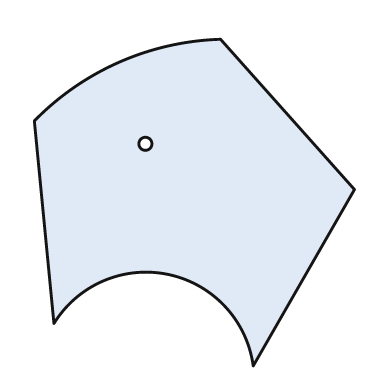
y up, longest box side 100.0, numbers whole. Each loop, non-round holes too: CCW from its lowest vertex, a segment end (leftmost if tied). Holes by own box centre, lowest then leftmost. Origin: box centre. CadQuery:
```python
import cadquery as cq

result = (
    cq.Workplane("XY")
    .moveTo(18.0, -50.0)
    .lineTo(49.0, 4.0)
    .lineTo(8.0, 50.0)
    .threePointArc((-23.0, 43.0), (-49.0, 25.0))
    .lineTo(-43.0, -37.0)
    .threePointArc((-8.0, -22.0), (18.0, -50.0))
    .close()
    .moveTo(-15.0, 18.0)
    .circle(2.0)
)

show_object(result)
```